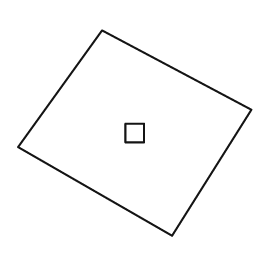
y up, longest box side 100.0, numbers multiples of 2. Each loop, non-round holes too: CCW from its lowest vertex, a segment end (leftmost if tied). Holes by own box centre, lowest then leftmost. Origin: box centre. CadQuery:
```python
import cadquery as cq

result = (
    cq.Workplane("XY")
    .moveTo(16.0, -44.0)
    .lineTo(50.0, 10.0)
    .lineTo(-14.0, 44.0)
    .lineTo(-50.0, -6.0)
    .close()
    .moveTo(-4.0, -4.0)
    .lineTo(4.0, -4.0)
    .lineTo(4.0, 4.0)
    .lineTo(-4.0, 4.0)
    .close()
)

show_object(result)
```